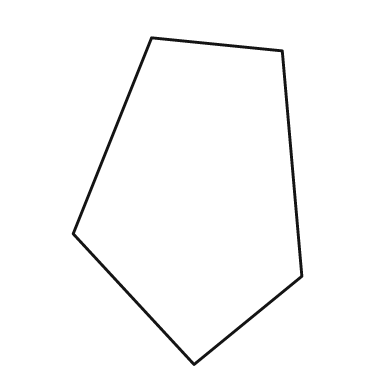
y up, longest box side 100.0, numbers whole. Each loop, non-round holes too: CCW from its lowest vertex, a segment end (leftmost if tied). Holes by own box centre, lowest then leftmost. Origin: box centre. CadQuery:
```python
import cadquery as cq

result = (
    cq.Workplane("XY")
    .moveTo(2.0, -50.0)
    .lineTo(35.0, -23.0)
    .lineTo(29.0, 46.0)
    .lineTo(-11.0, 50.0)
    .lineTo(-35.0, -10.0)
    .close()
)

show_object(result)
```